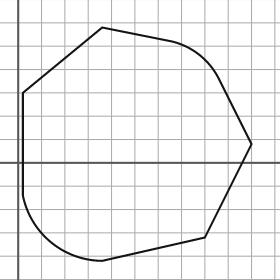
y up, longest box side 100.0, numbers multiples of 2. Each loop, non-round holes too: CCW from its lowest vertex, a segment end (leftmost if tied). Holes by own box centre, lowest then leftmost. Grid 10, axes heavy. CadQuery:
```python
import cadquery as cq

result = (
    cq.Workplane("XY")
    .moveTo(36.0, -42.0)
    .lineTo(80.0, -32.0)
    .lineTo(100.0, 8.0)
    .lineTo(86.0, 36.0)
    .threePointArc((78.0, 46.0), (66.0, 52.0))
    .lineTo(36.0, 58.0)
    .lineTo(2.0, 30.0)
    .lineTo(2.0, -14.0)
    .threePointArc((14.0, -34.0), (36.0, -42.0))
    .close()
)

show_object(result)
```